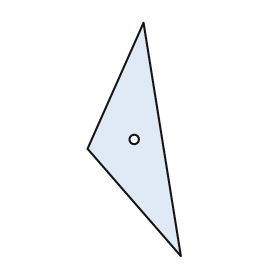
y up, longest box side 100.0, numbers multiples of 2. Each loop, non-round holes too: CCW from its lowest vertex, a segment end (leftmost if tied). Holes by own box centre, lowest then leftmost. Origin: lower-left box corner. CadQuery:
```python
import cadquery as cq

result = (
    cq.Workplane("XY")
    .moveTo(40.0, 0.0)
    .lineTo(24.0, 100.0)
    .lineTo(0.0, 46.0)
    .close()
    .moveTo(20.0, 50.0)
    .circle(2.0)
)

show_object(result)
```